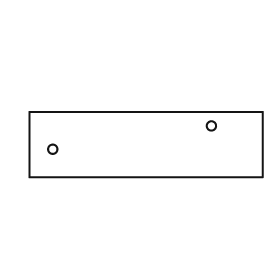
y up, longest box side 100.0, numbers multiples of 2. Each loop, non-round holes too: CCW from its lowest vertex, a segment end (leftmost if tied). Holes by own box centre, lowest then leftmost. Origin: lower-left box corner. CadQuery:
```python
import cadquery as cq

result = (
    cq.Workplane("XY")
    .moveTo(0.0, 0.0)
    .lineTo(100.0, 0.0)
    .lineTo(100.0, 28.0)
    .lineTo(0.0, 28.0)
    .close()
    .moveTo(10.0, 12.0)
    .circle(2.0)
    .moveTo(78.0, 22.0)
    .circle(2.0)
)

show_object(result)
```